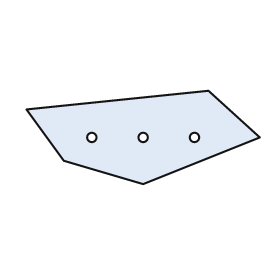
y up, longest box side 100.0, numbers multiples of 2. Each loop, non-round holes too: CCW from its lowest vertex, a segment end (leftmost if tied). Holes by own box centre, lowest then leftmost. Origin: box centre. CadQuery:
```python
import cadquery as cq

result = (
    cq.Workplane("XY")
    .moveTo(0.0, -20.0)
    .lineTo(50.0, 0.0)
    .lineTo(28.0, 20.0)
    .lineTo(-50.0, 12.0)
    .lineTo(-34.0, -10.0)
    .close()
    .moveTo(-22.0, 0.0)
    .circle(2.0)
    .moveTo(0.0, 0.0)
    .circle(2.0)
    .moveTo(22.0, 0.0)
    .circle(2.0)
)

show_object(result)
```